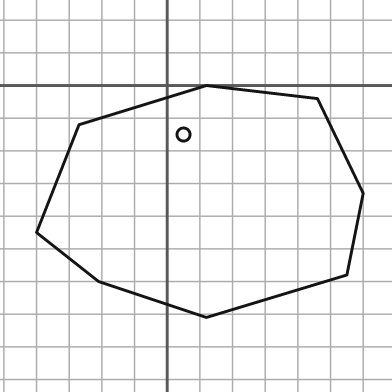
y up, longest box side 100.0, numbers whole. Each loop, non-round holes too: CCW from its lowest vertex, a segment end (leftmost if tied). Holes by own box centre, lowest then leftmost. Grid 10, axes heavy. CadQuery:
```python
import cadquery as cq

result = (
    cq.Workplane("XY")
    .moveTo(12.0, -71.0)
    .lineTo(55.0, -58.0)
    .lineTo(60.0, -33.0)
    .lineTo(46.0, -4.0)
    .lineTo(12.0, 0.0)
    .lineTo(-27.0, -12.0)
    .lineTo(-40.0, -45.0)
    .lineTo(-21.0, -60.0)
    .close()
    .moveTo(5.0, -15.0)
    .circle(2.0)
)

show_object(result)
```